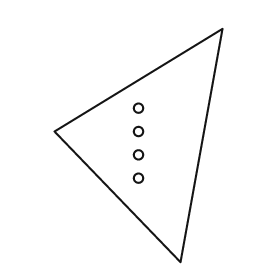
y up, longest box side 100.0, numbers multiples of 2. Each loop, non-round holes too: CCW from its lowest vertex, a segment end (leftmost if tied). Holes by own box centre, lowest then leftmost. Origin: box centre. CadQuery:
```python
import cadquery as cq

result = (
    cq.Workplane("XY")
    .moveTo(18.0, -50.0)
    .lineTo(36.0, 50.0)
    .lineTo(-36.0, 6.0)
    .close()
    .moveTo(0.0, -14.0)
    .circle(2.0)
    .moveTo(0.0, -4.0)
    .circle(2.0)
    .moveTo(0.0, 6.0)
    .circle(2.0)
    .moveTo(0.0, 16.0)
    .circle(2.0)
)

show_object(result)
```